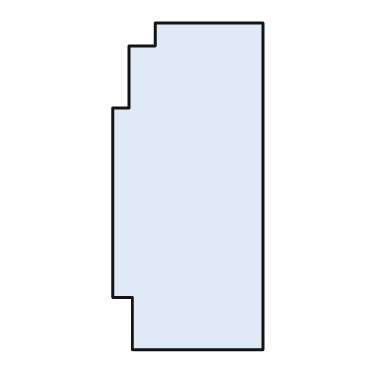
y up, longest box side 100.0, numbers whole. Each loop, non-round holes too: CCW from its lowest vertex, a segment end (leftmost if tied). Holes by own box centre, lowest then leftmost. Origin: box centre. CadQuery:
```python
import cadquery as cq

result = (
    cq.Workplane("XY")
    .moveTo(-17.0, -50.0)
    .lineTo(23.0, -50.0)
    .lineTo(23.0, 50.0)
    .lineTo(-10.0, 50.0)
    .lineTo(-10.0, 43.0)
    .lineTo(-18.0, 43.0)
    .lineTo(-18.0, 24.0)
    .lineTo(-23.0, 24.0)
    .lineTo(-23.0, -34.0)
    .lineTo(-17.0, -34.0)
    .close()
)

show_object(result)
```